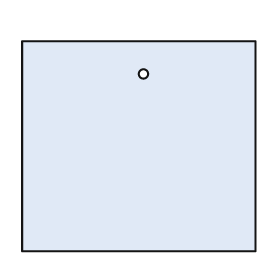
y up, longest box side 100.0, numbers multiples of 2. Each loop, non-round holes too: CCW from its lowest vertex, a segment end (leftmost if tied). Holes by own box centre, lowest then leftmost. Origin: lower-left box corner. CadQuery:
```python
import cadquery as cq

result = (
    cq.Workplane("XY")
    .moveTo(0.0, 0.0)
    .lineTo(100.0, 0.0)
    .lineTo(100.0, 90.0)
    .lineTo(0.0, 90.0)
    .close()
    .moveTo(52.0, 76.0)
    .circle(2.0)
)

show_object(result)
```